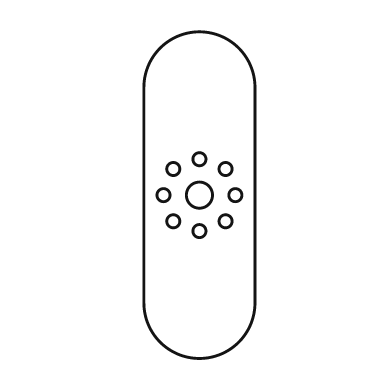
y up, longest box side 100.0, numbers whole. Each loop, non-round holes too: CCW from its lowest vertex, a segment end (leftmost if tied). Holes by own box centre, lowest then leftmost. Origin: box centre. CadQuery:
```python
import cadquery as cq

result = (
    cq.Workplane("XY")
    .moveTo(-17.0, -33.0)
    .threePointArc((0.0, -50.0), (17.0, -33.0))
    .lineTo(17.0, 33.0)
    .threePointArc((0.0, 50.0), (-17.0, 33.0))
    .close()
    .moveTo(0.0, -11.0)
    .circle(2.0)
    .moveTo(-8.0, -8.0)
    .circle(2.0)
    .moveTo(8.0, -8.0)
    .circle(2.0)
    .moveTo(-11.0, 0.0)
    .circle(2.0)
    .moveTo(0.0, 0.0)
    .circle(4.0)
    .moveTo(11.0, 0.0)
    .circle(2.0)
    .moveTo(-8.0, 8.0)
    .circle(2.0)
    .moveTo(8.0, 8.0)
    .circle(2.0)
    .moveTo(0.0, 11.0)
    .circle(2.0)
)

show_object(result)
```